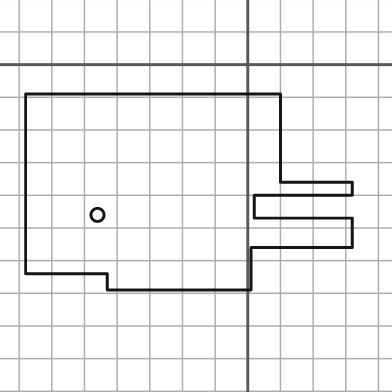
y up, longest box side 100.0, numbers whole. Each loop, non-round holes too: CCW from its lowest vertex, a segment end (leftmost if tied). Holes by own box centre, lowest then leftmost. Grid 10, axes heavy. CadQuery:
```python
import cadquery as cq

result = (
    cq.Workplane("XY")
    .moveTo(-43.0, -69.0)
    .lineTo(1.0, -69.0)
    .lineTo(1.0, -56.0)
    .lineTo(32.0, -56.0)
    .lineTo(32.0, -47.0)
    .lineTo(2.0, -47.0)
    .lineTo(2.0, -40.0)
    .lineTo(32.0, -40.0)
    .lineTo(32.0, -36.0)
    .lineTo(10.0, -36.0)
    .lineTo(10.0, -9.0)
    .lineTo(-68.0, -9.0)
    .lineTo(-68.0, -64.0)
    .lineTo(-43.0, -64.0)
    .close()
    .moveTo(-46.0, -46.0)
    .circle(2.0)
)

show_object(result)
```